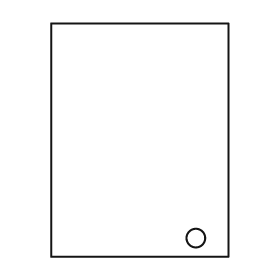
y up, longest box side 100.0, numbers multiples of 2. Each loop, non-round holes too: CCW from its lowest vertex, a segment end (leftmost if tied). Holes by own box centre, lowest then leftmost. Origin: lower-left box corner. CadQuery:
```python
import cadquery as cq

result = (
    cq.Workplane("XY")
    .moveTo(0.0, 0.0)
    .lineTo(76.0, 0.0)
    .lineTo(76.0, 100.0)
    .lineTo(0.0, 100.0)
    .close()
    .moveTo(62.0, 8.0)
    .circle(4.0)
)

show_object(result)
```